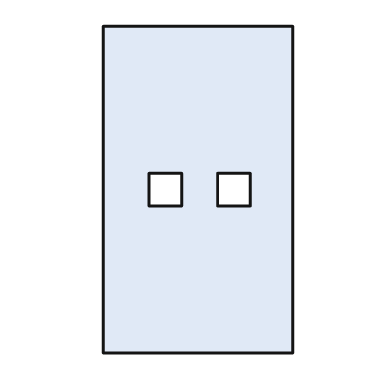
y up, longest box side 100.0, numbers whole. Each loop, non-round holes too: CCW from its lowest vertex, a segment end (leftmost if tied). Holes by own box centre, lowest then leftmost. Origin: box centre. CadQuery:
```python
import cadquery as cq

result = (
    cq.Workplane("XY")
    .moveTo(-29.0, -50.0)
    .lineTo(29.0, -50.0)
    .lineTo(29.0, 50.0)
    .lineTo(-29.0, 50.0)
    .close()
    .moveTo(-15.0, -5.0)
    .lineTo(-5.0, -5.0)
    .lineTo(-5.0, 5.0)
    .lineTo(-15.0, 5.0)
    .close()
    .moveTo(6.0, -5.0)
    .lineTo(16.0, -5.0)
    .lineTo(16.0, 5.0)
    .lineTo(6.0, 5.0)
    .close()
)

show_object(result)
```